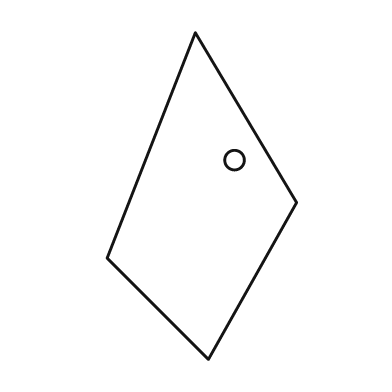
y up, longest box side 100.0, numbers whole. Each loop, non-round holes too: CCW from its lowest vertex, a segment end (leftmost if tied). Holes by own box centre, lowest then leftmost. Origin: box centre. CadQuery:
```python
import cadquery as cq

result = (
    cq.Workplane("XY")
    .moveTo(2.0, -50.0)
    .lineTo(29.0, -2.0)
    .lineTo(-2.0, 50.0)
    .lineTo(-29.0, -19.0)
    .close()
    .moveTo(10.0, 11.0)
    .circle(3.0)
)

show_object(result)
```